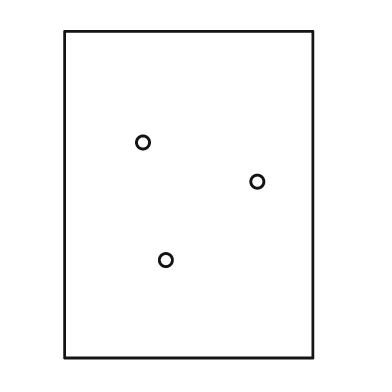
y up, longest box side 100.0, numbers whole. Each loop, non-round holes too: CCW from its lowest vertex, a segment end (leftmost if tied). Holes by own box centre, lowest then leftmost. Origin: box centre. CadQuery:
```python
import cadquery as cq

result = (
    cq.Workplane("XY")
    .moveTo(-38.0, -50.0)
    .lineTo(38.0, -50.0)
    .lineTo(38.0, 50.0)
    .lineTo(-38.0, 50.0)
    .close()
    .moveTo(-7.0, -20.0)
    .circle(2.0)
    .moveTo(21.0, 4.0)
    .circle(2.0)
    .moveTo(-14.0, 16.0)
    .circle(2.0)
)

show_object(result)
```